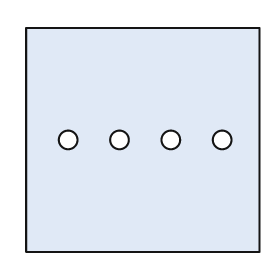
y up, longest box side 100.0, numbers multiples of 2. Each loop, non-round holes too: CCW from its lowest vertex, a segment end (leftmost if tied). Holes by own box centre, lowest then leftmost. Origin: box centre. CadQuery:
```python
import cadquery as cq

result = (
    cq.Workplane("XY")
    .moveTo(-50.0, -48.0)
    .lineTo(50.0, -48.0)
    .lineTo(50.0, 48.0)
    .lineTo(-50.0, 48.0)
    .close()
    .moveTo(-32.0, 0.0)
    .circle(4.0)
    .moveTo(-10.0, 0.0)
    .circle(4.0)
    .moveTo(12.0, 0.0)
    .circle(4.0)
    .moveTo(34.0, 0.0)
    .circle(4.0)
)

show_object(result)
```